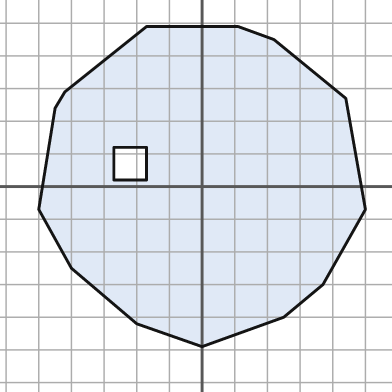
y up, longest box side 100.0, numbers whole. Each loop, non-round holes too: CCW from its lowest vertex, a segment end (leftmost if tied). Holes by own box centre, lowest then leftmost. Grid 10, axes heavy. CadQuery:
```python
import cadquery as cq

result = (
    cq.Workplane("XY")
    .moveTo(0.0, -49.0)
    .lineTo(25.0, -40.0)
    .lineTo(37.0, -30.0)
    .lineTo(50.0, -7.0)
    .lineTo(44.0, 27.0)
    .lineTo(22.0, 45.0)
    .lineTo(11.0, 49.0)
    .lineTo(-17.0, 49.0)
    .lineTo(-42.0, 29.0)
    .lineTo(-45.0, 24.0)
    .lineTo(-50.0, -7.0)
    .lineTo(-40.0, -25.0)
    .lineTo(-20.0, -42.0)
    .close()
    .moveTo(-27.0, 2.0)
    .lineTo(-17.0, 2.0)
    .lineTo(-17.0, 12.0)
    .lineTo(-27.0, 12.0)
    .close()
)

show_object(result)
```